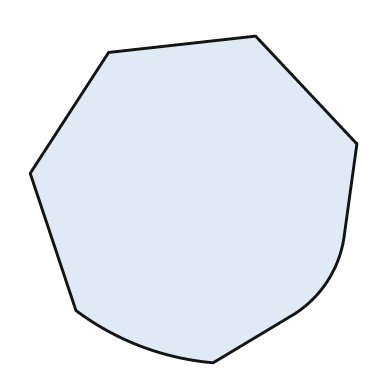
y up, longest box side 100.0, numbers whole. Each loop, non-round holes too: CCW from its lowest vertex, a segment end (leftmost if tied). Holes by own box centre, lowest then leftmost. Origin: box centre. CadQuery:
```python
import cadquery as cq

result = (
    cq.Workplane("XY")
    .moveTo(6.0, -50.0)
    .lineTo(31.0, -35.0)
    .threePointArc((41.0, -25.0), (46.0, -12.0))
    .lineTo(50.0, 17.0)
    .lineTo(19.0, 50.0)
    .lineTo(-26.0, 45.0)
    .lineTo(-50.0, 8.0)
    .lineTo(-36.0, -34.0)
    .threePointArc((-16.0, -45.0), (6.0, -50.0))
    .close()
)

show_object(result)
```